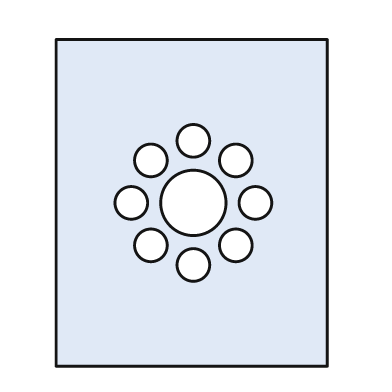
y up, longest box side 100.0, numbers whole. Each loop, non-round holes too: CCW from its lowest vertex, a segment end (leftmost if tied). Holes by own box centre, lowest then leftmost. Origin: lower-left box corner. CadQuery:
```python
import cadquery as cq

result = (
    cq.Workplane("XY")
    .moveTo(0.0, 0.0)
    .lineTo(83.0, 0.0)
    .lineTo(83.0, 100.0)
    .lineTo(0.0, 100.0)
    .close()
    .moveTo(42.0, 31.0)
    .circle(5.0)
    .moveTo(29.0, 37.0)
    .circle(5.0)
    .moveTo(55.0, 37.0)
    .circle(5.0)
    .moveTo(23.0, 50.0)
    .circle(5.0)
    .moveTo(42.0, 50.0)
    .circle(10.0)
    .moveTo(61.0, 50.0)
    .circle(5.0)
    .moveTo(29.0, 63.0)
    .circle(5.0)
    .moveTo(55.0, 63.0)
    .circle(5.0)
    .moveTo(42.0, 69.0)
    .circle(5.0)
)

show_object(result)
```